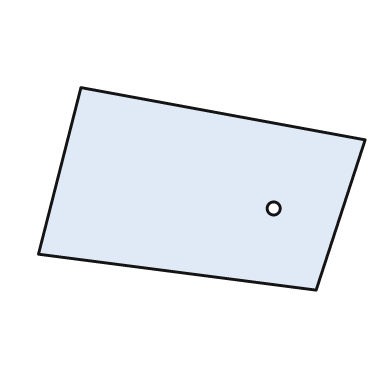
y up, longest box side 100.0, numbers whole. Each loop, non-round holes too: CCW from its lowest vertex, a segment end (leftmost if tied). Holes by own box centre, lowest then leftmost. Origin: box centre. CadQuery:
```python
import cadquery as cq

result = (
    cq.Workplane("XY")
    .moveTo(35.0, -31.0)
    .lineTo(50.0, 15.0)
    .lineTo(-37.0, 31.0)
    .lineTo(-50.0, -20.0)
    .close()
    .moveTo(22.0, -6.0)
    .circle(2.0)
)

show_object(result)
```